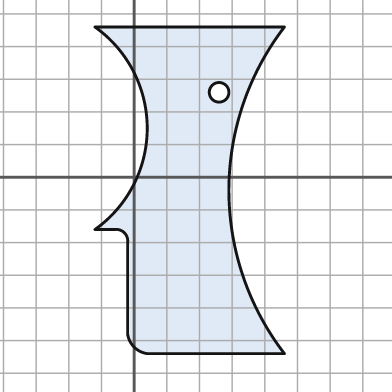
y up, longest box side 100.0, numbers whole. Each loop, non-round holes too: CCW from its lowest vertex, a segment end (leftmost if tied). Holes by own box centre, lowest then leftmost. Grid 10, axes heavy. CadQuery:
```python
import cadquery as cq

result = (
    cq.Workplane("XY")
    .moveTo(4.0, -54.0)
    .lineTo(46.0, -54.0)
    .threePointArc((29.0, -4.0), (46.0, 46.0))
    .lineTo(-12.0, 46.0)
    .threePointArc((4.0, 15.0), (-12.0, -16.0))
    .lineTo(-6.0, -16.0)
    .threePointArc((-3.0, -17.0), (-2.0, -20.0))
    .lineTo(-2.0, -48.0)
    .threePointArc((0.0, -52.0), (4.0, -54.0))
    .close()
    .moveTo(26.0, 26.0)
    .circle(3.0)
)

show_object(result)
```